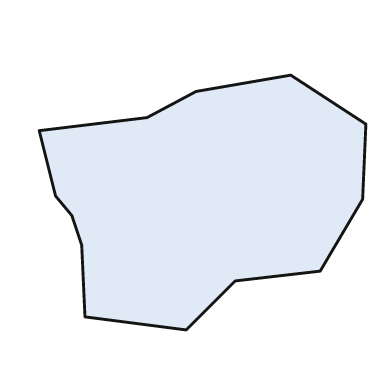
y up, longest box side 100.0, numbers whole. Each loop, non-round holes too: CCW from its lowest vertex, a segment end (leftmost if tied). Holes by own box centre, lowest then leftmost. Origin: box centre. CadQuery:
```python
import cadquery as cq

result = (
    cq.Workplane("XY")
    .moveTo(-5.0, -39.0)
    .lineTo(10.0, -24.0)
    .lineTo(36.0, -21.0)
    .lineTo(49.0, 1.0)
    .lineTo(50.0, 24.0)
    .lineTo(27.0, 39.0)
    .lineTo(-2.0, 34.0)
    .lineTo(-17.0, 26.0)
    .lineTo(-50.0, 22.0)
    .lineTo(-45.0, 2.0)
    .lineTo(-40.0, -4.0)
    .lineTo(-37.0, -13.0)
    .lineTo(-36.0, -35.0)
    .close()
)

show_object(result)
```